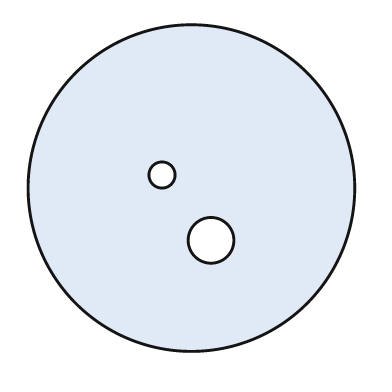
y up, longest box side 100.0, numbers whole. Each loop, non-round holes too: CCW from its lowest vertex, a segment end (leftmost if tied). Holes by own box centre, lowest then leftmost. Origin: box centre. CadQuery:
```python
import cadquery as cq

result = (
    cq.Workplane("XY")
    .moveTo(0.0, 0.0)
    .circle(50.0)
    .moveTo(6.0, -16.0)
    .circle(7.0)
    .moveTo(-9.0, 4.0)
    .circle(4.0)
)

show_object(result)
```